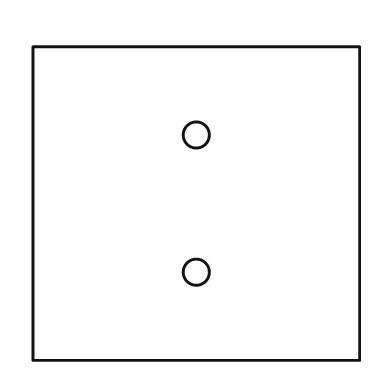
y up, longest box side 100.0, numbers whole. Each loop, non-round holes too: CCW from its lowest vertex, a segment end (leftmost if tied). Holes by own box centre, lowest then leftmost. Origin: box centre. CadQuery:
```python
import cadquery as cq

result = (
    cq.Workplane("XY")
    .moveTo(-50.0, -48.0)
    .lineTo(50.0, -48.0)
    .lineTo(50.0, 48.0)
    .lineTo(-50.0, 48.0)
    .close()
    .moveTo(0.0, -21.0)
    .circle(4.0)
    .moveTo(0.0, 21.0)
    .circle(4.0)
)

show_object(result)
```